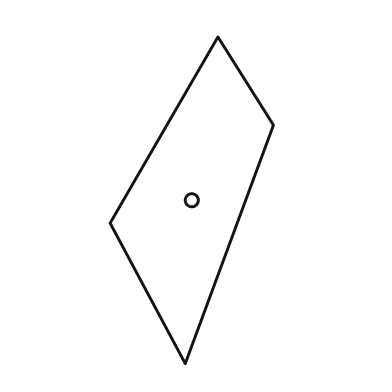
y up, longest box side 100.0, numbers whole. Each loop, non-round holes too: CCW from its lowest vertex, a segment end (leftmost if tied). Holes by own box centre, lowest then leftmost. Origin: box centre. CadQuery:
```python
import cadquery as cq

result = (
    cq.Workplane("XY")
    .moveTo(-2.0, -50.0)
    .lineTo(25.0, 23.0)
    .lineTo(8.0, 50.0)
    .lineTo(-25.0, -7.0)
    .close()
    .moveTo(0.0, 0.0)
    .circle(2.0)
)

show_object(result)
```